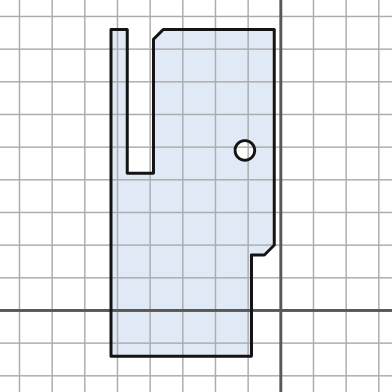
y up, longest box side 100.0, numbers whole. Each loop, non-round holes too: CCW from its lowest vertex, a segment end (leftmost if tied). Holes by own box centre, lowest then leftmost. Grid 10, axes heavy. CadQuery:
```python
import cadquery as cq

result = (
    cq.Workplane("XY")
    .moveTo(-52.0, -14.0)
    .lineTo(-9.0, -14.0)
    .lineTo(-9.0, 17.0)
    .lineTo(-5.0, 17.0)
    .lineTo(-2.0, 20.0)
    .lineTo(-2.0, 86.0)
    .lineTo(-36.0, 86.0)
    .lineTo(-39.0, 83.0)
    .lineTo(-39.0, 42.0)
    .lineTo(-47.0, 42.0)
    .lineTo(-47.0, 86.0)
    .lineTo(-52.0, 86.0)
    .close()
    .moveTo(-11.0, 49.0)
    .circle(3.0)
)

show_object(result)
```